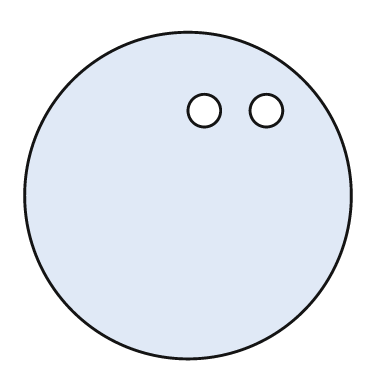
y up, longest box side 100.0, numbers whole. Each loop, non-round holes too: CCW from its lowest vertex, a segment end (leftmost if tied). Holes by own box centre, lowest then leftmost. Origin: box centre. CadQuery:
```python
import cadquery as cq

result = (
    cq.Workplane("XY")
    .moveTo(0.0, 0.0)
    .circle(50.0)
    .moveTo(5.0, 26.0)
    .circle(5.0)
    .moveTo(24.0, 26.0)
    .circle(5.0)
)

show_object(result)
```